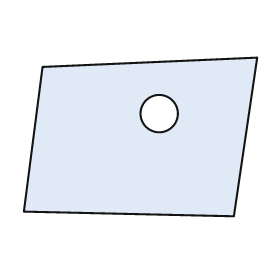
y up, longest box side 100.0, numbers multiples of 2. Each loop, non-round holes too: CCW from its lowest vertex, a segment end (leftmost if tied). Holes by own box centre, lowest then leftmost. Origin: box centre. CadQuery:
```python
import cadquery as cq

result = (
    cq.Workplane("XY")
    .moveTo(40.0, -34.0)
    .lineTo(50.0, 34.0)
    .lineTo(-42.0, 30.0)
    .lineTo(-50.0, -32.0)
    .close()
    .moveTo(8.0, 10.0)
    .circle(8.0)
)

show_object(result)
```